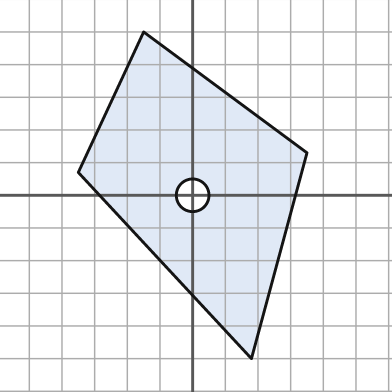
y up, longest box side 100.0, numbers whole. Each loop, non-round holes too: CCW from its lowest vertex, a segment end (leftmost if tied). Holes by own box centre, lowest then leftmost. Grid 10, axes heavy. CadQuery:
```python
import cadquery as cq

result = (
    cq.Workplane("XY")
    .moveTo(18.0, -50.0)
    .lineTo(35.0, 13.0)
    .lineTo(-15.0, 50.0)
    .lineTo(-35.0, 7.0)
    .close()
    .moveTo(0.0, 0.0)
    .circle(5.0)
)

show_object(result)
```